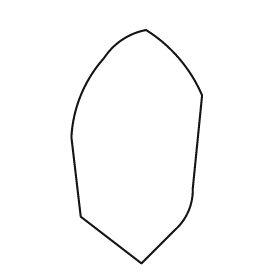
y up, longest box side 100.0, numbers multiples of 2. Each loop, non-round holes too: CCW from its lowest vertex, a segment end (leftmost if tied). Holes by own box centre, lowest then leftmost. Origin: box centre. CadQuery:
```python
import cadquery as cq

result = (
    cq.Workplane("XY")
    .moveTo(2.0, -50.0)
    .lineTo(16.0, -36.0)
    .threePointArc((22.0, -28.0), (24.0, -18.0))
    .lineTo(28.0, 22.0)
    .threePointArc((18.0, 38.0), (4.0, 50.0))
    .threePointArc((-6.0, 46.0), (-14.0, 38.0))
    .threePointArc((-24.0, 22.0), (-28.0, 4.0))
    .lineTo(-24.0, -30.0)
    .close()
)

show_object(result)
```